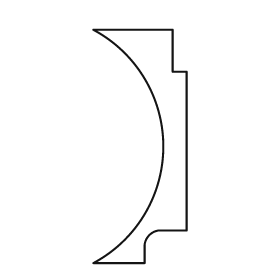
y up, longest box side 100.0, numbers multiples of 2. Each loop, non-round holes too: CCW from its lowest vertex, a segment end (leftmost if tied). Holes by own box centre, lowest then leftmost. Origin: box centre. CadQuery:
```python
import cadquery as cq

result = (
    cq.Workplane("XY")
    .moveTo(-20.0, -50.0)
    .lineTo(2.0, -50.0)
    .lineTo(2.0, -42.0)
    .threePointArc((4.0, -38.0), (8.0, -36.0))
    .lineTo(20.0, -36.0)
    .lineTo(20.0, 32.0)
    .lineTo(14.0, 32.0)
    .lineTo(14.0, 50.0)
    .lineTo(-20.0, 50.0)
    .threePointArc((10.0, 0.0), (-20.0, -50.0))
    .close()
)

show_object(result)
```